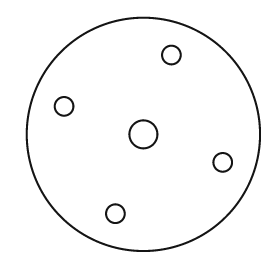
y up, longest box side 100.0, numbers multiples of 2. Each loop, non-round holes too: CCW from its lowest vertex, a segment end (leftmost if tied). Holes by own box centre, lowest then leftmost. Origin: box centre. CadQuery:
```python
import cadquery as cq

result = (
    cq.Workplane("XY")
    .moveTo(0.0, 0.0)
    .circle(50.0)
    .moveTo(-12.0, -34.0)
    .circle(4.0)
    .moveTo(34.0, -12.0)
    .circle(4.0)
    .moveTo(0.0, 0.0)
    .circle(6.0)
    .moveTo(-34.0, 12.0)
    .circle(4.0)
    .moveTo(12.0, 34.0)
    .circle(4.0)
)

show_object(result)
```